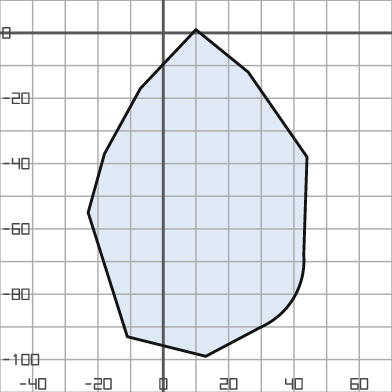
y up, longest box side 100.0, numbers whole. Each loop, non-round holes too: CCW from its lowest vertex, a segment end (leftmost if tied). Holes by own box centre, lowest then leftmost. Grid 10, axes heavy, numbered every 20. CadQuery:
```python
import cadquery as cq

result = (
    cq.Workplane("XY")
    .moveTo(13.0, -99.0)
    .lineTo(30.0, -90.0)
    .threePointArc((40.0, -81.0), (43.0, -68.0))
    .lineTo(44.0, -38.0)
    .lineTo(26.0, -12.0)
    .lineTo(10.0, 1.0)
    .lineTo(-7.0, -17.0)
    .lineTo(-18.0, -37.0)
    .lineTo(-23.0, -55.0)
    .lineTo(-11.0, -93.0)
    .close()
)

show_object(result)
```